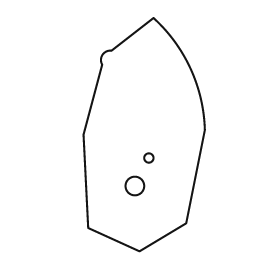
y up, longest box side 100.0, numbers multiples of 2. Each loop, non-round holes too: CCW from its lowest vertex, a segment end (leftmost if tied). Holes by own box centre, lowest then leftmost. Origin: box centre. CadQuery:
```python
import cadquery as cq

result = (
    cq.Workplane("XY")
    .moveTo(-2.0, -50.0)
    .lineTo(18.0, -38.0)
    .lineTo(26.0, 2.0)
    .threePointArc((20.0, 28.0), (4.0, 50.0))
    .lineTo(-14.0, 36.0)
    .threePointArc((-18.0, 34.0), (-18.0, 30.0))
    .lineTo(-26.0, 0.0)
    .lineTo(-24.0, -40.0)
    .close()
    .moveTo(-4.0, -22.0)
    .circle(4.0)
    .moveTo(2.0, -10.0)
    .circle(2.0)
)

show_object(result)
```